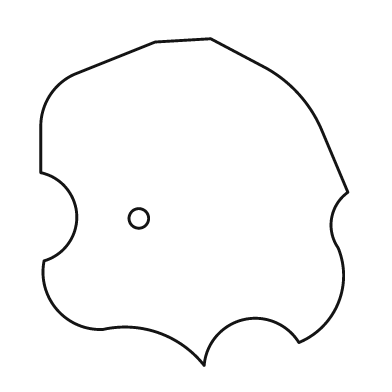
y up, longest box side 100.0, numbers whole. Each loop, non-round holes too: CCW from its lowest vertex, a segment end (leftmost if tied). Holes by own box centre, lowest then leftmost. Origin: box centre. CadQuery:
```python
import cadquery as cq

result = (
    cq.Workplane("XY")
    .moveTo(3.0, -50.0)
    .threePointArc((15.0, -36.0), (32.0, -43.0))
    .threePointArc((44.0, -31.0), (44.0, -14.0))
    .threePointArc((42.0, -5.0), (47.0, 3.0))
    .lineTo(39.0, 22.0)
    .threePointArc((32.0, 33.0), (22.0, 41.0))
    .lineTo(5.0, 50.0)
    .lineTo(-12.0, 49.0)
    .lineTo(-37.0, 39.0)
    .threePointArc((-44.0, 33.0), (-47.0, 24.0))
    .lineTo(-47.0, 9.0)
    .threePointArc((-36.0, -4.0), (-46.0, -18.0))
    .threePointArc((-42.0, -33.0), (-28.0, -39.0))
    .threePointArc((-11.0, -40.0), (3.0, -50.0))
    .close()
    .moveTo(-17.0, -5.0)
    .circle(3.0)
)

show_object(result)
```